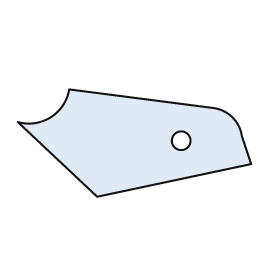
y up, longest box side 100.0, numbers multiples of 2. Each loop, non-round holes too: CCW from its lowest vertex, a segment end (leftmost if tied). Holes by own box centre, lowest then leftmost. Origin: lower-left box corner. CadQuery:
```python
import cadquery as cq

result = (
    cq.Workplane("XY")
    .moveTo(34.0, 0.0)
    .lineTo(100.0, 14.0)
    .lineTo(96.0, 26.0)
    .threePointArc((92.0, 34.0), (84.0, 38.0))
    .lineTo(22.0, 46.0)
    .threePointArc((14.0, 34.0), (0.0, 32.0))
    .close()
    .moveTo(70.0, 24.0)
    .circle(4.0)
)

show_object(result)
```